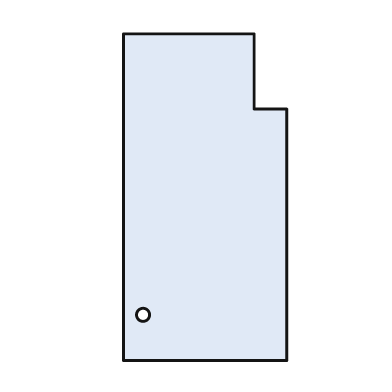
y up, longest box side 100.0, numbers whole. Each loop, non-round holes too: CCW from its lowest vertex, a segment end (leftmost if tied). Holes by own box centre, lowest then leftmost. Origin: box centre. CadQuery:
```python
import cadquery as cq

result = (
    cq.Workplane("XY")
    .moveTo(-25.0, -50.0)
    .lineTo(25.0, -50.0)
    .lineTo(25.0, 27.0)
    .lineTo(15.0, 27.0)
    .lineTo(15.0, 50.0)
    .lineTo(-25.0, 50.0)
    .close()
    .moveTo(-19.0, -36.0)
    .circle(2.0)
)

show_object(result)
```